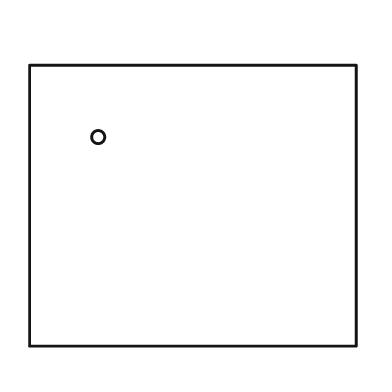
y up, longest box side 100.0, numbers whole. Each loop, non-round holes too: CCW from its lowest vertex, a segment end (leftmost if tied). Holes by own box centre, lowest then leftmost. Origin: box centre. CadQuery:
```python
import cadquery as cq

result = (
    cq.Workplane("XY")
    .moveTo(-50.0, -43.0)
    .lineTo(50.0, -43.0)
    .lineTo(50.0, 43.0)
    .lineTo(-50.0, 43.0)
    .close()
    .moveTo(-29.0, 21.0)
    .circle(2.0)
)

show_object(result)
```